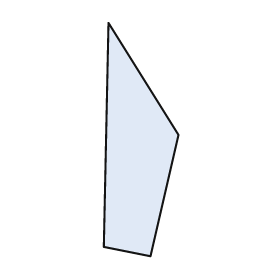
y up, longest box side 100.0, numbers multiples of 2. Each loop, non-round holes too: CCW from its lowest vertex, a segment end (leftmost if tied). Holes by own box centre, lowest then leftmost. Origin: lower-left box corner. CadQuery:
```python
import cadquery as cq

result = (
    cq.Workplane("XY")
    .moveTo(20.0, 0.0)
    .lineTo(32.0, 52.0)
    .lineTo(2.0, 100.0)
    .lineTo(0.0, 4.0)
    .close()
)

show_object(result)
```